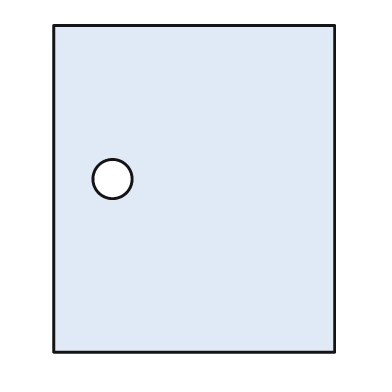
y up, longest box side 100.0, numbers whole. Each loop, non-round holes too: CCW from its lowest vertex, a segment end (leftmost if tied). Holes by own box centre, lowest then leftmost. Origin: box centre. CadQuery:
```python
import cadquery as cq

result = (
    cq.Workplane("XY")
    .moveTo(-43.0, -50.0)
    .lineTo(43.0, -50.0)
    .lineTo(43.0, 50.0)
    .lineTo(-43.0, 50.0)
    .close()
    .moveTo(-25.0, 3.0)
    .circle(6.0)
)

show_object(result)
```